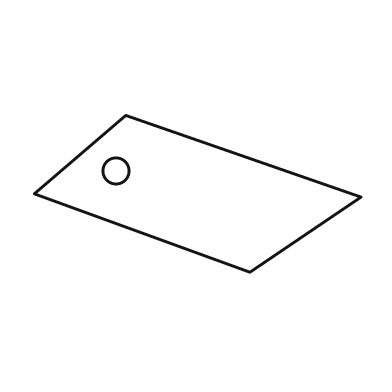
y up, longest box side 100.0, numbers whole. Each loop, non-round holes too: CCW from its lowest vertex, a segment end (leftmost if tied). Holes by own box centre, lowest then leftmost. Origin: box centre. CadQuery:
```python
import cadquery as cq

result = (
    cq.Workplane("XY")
    .moveTo(16.0, -24.0)
    .lineTo(50.0, -1.0)
    .lineTo(-22.0, 24.0)
    .lineTo(-50.0, 0.0)
    .close()
    .moveTo(-25.0, 7.0)
    .circle(4.0)
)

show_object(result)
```